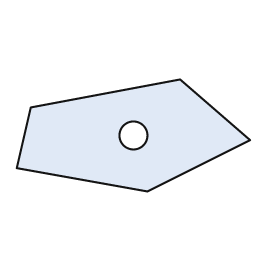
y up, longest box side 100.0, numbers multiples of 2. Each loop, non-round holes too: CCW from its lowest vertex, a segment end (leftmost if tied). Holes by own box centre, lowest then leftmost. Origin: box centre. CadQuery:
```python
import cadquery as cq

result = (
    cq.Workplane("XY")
    .moveTo(6.0, -24.0)
    .lineTo(50.0, -2.0)
    .lineTo(20.0, 24.0)
    .lineTo(-44.0, 12.0)
    .lineTo(-50.0, -14.0)
    .close()
    .moveTo(0.0, 0.0)
    .circle(6.0)
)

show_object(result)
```